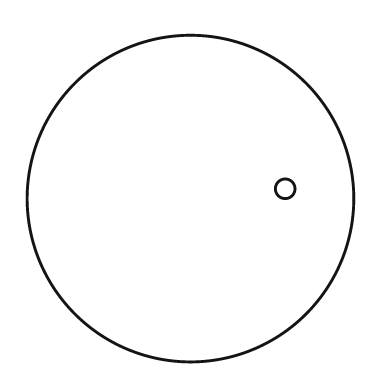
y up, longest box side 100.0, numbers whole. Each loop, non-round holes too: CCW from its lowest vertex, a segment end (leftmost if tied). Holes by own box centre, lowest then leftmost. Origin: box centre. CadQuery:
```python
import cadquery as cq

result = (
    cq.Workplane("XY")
    .moveTo(0.0, 0.0)
    .circle(50.0)
    .moveTo(29.0, 3.0)
    .circle(3.0)
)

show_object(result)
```